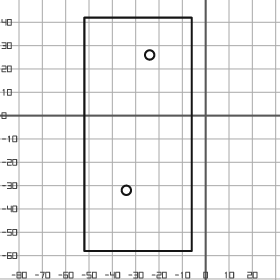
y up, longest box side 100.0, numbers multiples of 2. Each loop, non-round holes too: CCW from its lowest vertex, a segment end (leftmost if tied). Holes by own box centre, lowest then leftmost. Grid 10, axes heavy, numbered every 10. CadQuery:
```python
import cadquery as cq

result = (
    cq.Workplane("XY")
    .moveTo(-52.0, -58.0)
    .lineTo(-6.0, -58.0)
    .lineTo(-6.0, 42.0)
    .lineTo(-52.0, 42.0)
    .close()
    .moveTo(-34.0, -32.0)
    .circle(2.0)
    .moveTo(-24.0, 26.0)
    .circle(2.0)
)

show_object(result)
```